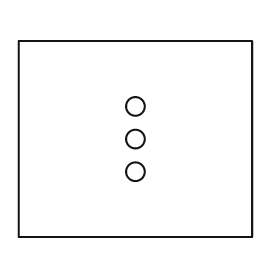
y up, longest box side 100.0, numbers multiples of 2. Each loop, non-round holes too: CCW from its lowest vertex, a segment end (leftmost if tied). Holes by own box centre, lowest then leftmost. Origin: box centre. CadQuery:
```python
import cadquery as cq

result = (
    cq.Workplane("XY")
    .moveTo(-50.0, -42.0)
    .lineTo(50.0, -42.0)
    .lineTo(50.0, 42.0)
    .lineTo(-50.0, 42.0)
    .close()
    .moveTo(0.0, -14.0)
    .circle(4.0)
    .moveTo(0.0, 0.0)
    .circle(4.0)
    .moveTo(0.0, 14.0)
    .circle(4.0)
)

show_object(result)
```